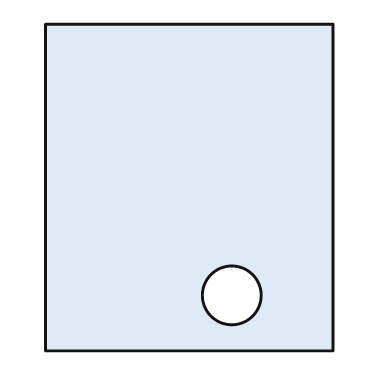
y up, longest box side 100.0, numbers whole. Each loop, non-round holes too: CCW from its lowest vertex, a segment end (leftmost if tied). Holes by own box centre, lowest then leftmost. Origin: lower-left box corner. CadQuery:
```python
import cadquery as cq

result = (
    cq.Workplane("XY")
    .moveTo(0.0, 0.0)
    .lineTo(88.0, 0.0)
    .lineTo(88.0, 100.0)
    .lineTo(0.0, 100.0)
    .close()
    .moveTo(57.0, 17.0)
    .circle(9.0)
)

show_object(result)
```